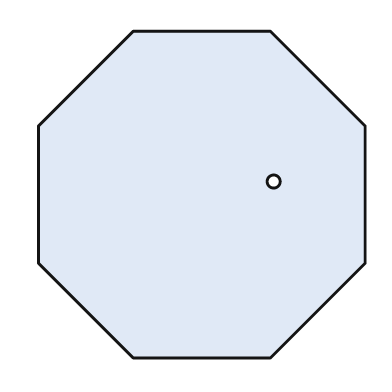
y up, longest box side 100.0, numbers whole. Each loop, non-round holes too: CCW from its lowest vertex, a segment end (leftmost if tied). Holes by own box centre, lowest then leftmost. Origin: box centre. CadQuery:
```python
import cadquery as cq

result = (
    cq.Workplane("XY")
    .moveTo(-21.0, -50.0)
    .lineTo(21.0, -50.0)
    .lineTo(50.0, -21.0)
    .lineTo(50.0, 21.0)
    .lineTo(21.0, 50.0)
    .lineTo(-21.0, 50.0)
    .lineTo(-50.0, 21.0)
    .lineTo(-50.0, -21.0)
    .close()
    .moveTo(22.0, 4.0)
    .circle(2.0)
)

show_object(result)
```